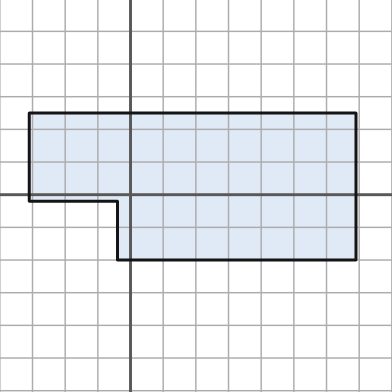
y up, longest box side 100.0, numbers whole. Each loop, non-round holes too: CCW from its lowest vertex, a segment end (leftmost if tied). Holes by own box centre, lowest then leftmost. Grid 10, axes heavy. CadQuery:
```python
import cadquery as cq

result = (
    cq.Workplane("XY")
    .moveTo(-4.0, -20.0)
    .lineTo(69.0, -20.0)
    .lineTo(69.0, 25.0)
    .lineTo(-31.0, 25.0)
    .lineTo(-31.0, -2.0)
    .lineTo(-4.0, -2.0)
    .close()
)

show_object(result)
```